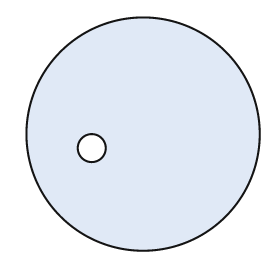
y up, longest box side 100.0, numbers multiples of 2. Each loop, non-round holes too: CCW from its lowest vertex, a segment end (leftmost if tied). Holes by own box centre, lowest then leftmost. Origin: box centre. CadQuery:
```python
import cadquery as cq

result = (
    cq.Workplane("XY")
    .moveTo(0.0, 0.0)
    .circle(50.0)
    .moveTo(-22.0, -6.0)
    .circle(6.0)
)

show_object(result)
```